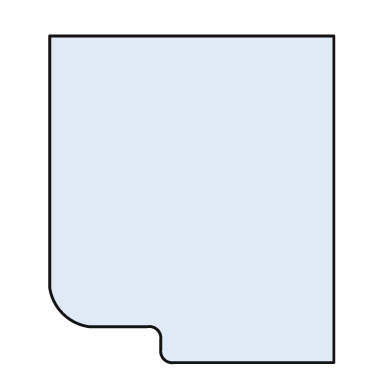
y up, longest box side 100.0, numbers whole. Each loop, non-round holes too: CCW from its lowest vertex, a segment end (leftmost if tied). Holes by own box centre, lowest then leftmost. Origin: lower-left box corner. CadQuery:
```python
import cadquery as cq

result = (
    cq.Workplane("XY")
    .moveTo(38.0, 0.0)
    .lineTo(87.0, 0.0)
    .lineTo(87.0, 100.0)
    .lineTo(0.0, 100.0)
    .lineTo(0.0, 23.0)
    .threePointArc((4.0, 15.0), (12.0, 11.0))
    .lineTo(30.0, 11.0)
    .threePointArc((33.0, 10.0), (34.0, 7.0))
    .lineTo(34.0, 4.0)
    .threePointArc((35.0, 1.0), (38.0, 0.0))
    .close()
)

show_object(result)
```